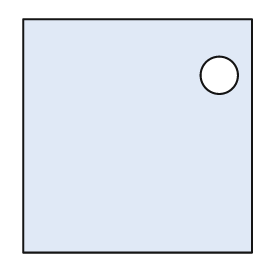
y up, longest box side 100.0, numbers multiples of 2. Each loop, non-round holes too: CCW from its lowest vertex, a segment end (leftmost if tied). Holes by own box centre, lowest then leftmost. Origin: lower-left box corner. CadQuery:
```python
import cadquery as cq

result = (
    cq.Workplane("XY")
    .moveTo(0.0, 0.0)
    .lineTo(98.0, 0.0)
    .lineTo(98.0, 100.0)
    .lineTo(0.0, 100.0)
    .close()
    .moveTo(84.0, 76.0)
    .circle(8.0)
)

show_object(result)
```